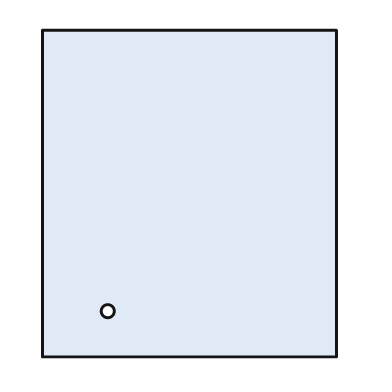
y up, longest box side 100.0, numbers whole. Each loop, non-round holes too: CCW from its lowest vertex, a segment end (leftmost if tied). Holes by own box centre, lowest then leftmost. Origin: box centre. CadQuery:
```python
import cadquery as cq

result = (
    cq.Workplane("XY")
    .moveTo(-45.0, -50.0)
    .lineTo(45.0, -50.0)
    .lineTo(45.0, 50.0)
    .lineTo(-45.0, 50.0)
    .close()
    .moveTo(-25.0, -36.0)
    .circle(2.0)
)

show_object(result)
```